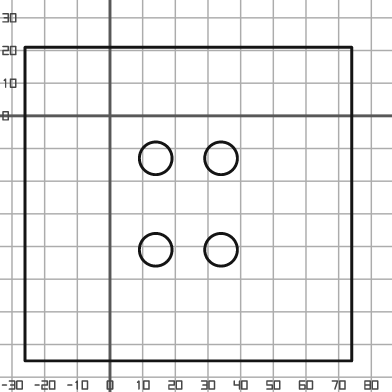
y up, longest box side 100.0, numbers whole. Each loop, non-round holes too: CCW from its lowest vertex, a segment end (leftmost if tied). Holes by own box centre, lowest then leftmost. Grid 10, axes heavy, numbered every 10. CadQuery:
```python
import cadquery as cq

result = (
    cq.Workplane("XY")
    .moveTo(-26.0, -75.0)
    .lineTo(74.0, -75.0)
    .lineTo(74.0, 21.0)
    .lineTo(-26.0, 21.0)
    .close()
    .moveTo(14.0, -41.0)
    .circle(5.0)
    .moveTo(34.0, -41.0)
    .circle(5.0)
    .moveTo(14.0, -13.0)
    .circle(5.0)
    .moveTo(34.0, -13.0)
    .circle(5.0)
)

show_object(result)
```